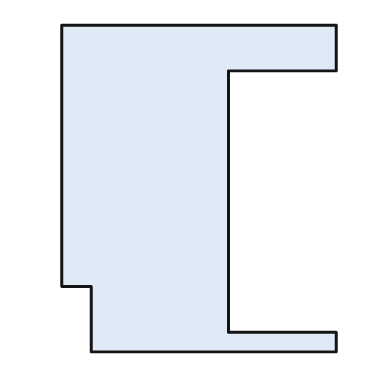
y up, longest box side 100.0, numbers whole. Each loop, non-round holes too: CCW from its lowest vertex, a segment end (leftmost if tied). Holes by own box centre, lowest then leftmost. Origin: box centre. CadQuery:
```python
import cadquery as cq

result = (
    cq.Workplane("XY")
    .moveTo(-33.0, -50.0)
    .lineTo(42.0, -50.0)
    .lineTo(42.0, -44.0)
    .lineTo(9.0, -44.0)
    .lineTo(9.0, 36.0)
    .lineTo(42.0, 36.0)
    .lineTo(42.0, 50.0)
    .lineTo(-42.0, 50.0)
    .lineTo(-42.0, -30.0)
    .lineTo(-33.0, -30.0)
    .close()
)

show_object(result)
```